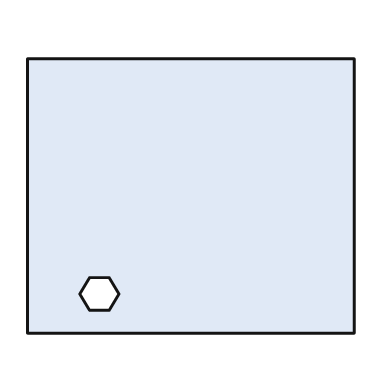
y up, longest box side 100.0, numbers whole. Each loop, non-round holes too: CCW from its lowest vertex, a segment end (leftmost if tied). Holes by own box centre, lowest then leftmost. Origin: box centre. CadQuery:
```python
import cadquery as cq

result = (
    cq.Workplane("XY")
    .moveTo(-50.0, -42.0)
    .lineTo(50.0, -42.0)
    .lineTo(50.0, 42.0)
    .lineTo(-50.0, 42.0)
    .close()
    .moveTo(-31.0, -35.0)
    .lineTo(-25.0, -35.0)
    .lineTo(-22.0, -30.0)
    .lineTo(-25.0, -25.0)
    .lineTo(-31.0, -25.0)
    .lineTo(-34.0, -30.0)
    .close()
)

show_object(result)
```